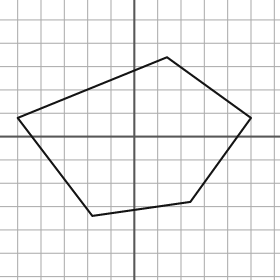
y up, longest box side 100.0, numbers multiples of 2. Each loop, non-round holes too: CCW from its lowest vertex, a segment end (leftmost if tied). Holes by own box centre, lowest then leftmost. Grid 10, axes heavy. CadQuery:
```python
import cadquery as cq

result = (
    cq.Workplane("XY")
    .moveTo(-18.0, -34.0)
    .lineTo(24.0, -28.0)
    .lineTo(50.0, 8.0)
    .lineTo(14.0, 34.0)
    .lineTo(-50.0, 8.0)
    .close()
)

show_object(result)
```